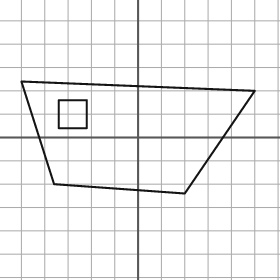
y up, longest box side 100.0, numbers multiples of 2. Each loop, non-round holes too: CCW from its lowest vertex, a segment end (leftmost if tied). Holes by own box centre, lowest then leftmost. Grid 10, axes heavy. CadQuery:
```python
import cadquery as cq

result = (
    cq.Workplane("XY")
    .moveTo(20.0, -24.0)
    .lineTo(50.0, 20.0)
    .lineTo(-50.0, 24.0)
    .lineTo(-36.0, -20.0)
    .close()
    .moveTo(-34.0, 4.0)
    .lineTo(-22.0, 4.0)
    .lineTo(-22.0, 16.0)
    .lineTo(-34.0, 16.0)
    .close()
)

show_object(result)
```